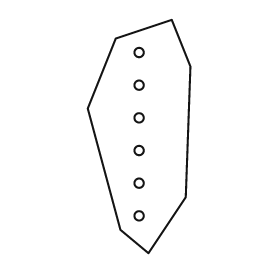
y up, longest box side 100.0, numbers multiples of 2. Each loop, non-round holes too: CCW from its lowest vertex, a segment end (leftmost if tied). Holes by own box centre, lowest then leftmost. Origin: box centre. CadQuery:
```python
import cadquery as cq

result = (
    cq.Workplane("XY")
    .moveTo(4.0, -50.0)
    .lineTo(20.0, -26.0)
    .lineTo(22.0, 30.0)
    .lineTo(14.0, 50.0)
    .lineTo(-10.0, 42.0)
    .lineTo(-22.0, 12.0)
    .lineTo(-8.0, -40.0)
    .close()
    .moveTo(0.0, -34.0)
    .circle(2.0)
    .moveTo(0.0, -20.0)
    .circle(2.0)
    .moveTo(0.0, -6.0)
    .circle(2.0)
    .moveTo(0.0, 8.0)
    .circle(2.0)
    .moveTo(0.0, 22.0)
    .circle(2.0)
    .moveTo(0.0, 36.0)
    .circle(2.0)
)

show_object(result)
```